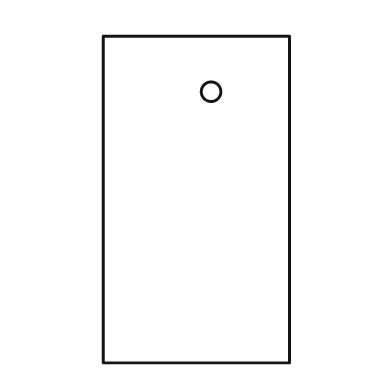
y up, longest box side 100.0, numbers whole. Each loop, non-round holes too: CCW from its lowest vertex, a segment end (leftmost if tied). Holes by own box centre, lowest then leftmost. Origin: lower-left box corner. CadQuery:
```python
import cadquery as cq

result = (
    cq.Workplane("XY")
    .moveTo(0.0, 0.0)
    .lineTo(57.0, 0.0)
    .lineTo(57.0, 100.0)
    .lineTo(0.0, 100.0)
    .close()
    .moveTo(33.0, 83.0)
    .circle(3.0)
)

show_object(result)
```